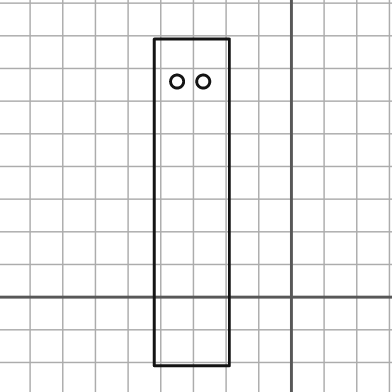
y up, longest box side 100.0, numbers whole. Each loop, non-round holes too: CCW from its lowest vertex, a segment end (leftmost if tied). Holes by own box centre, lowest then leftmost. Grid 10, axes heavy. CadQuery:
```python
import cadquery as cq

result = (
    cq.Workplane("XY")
    .moveTo(-42.0, -21.0)
    .lineTo(-19.0, -21.0)
    .lineTo(-19.0, 79.0)
    .lineTo(-42.0, 79.0)
    .close()
    .moveTo(-35.0, 66.0)
    .circle(2.0)
    .moveTo(-27.0, 66.0)
    .circle(2.0)
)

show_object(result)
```